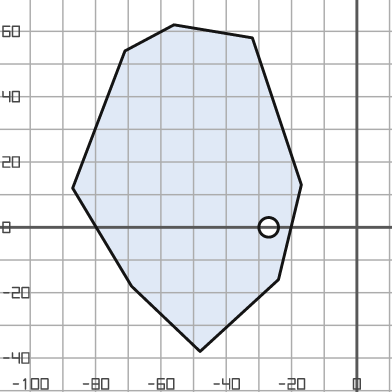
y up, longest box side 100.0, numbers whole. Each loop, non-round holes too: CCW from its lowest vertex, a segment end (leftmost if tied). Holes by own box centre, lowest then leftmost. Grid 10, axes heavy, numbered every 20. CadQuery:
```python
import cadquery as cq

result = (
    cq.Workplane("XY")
    .moveTo(-48.0, -38.0)
    .lineTo(-24.0, -16.0)
    .lineTo(-17.0, 13.0)
    .lineTo(-32.0, 58.0)
    .lineTo(-56.0, 62.0)
    .lineTo(-71.0, 54.0)
    .lineTo(-87.0, 12.0)
    .lineTo(-69.0, -18.0)
    .close()
    .moveTo(-27.0, 0.0)
    .circle(3.0)
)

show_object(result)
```